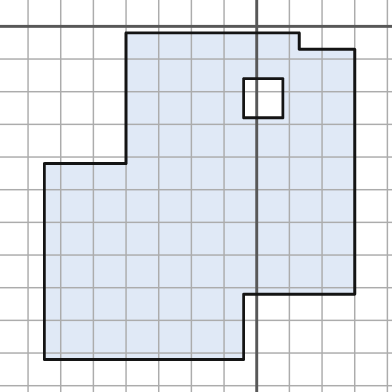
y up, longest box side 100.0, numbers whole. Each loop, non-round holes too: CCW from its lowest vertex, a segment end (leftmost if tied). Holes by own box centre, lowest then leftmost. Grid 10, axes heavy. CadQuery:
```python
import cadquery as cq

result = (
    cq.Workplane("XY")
    .moveTo(-65.0, -102.0)
    .lineTo(-4.0, -102.0)
    .lineTo(-4.0, -82.0)
    .lineTo(30.0, -82.0)
    .lineTo(30.0, -7.0)
    .lineTo(13.0, -7.0)
    .lineTo(13.0, -2.0)
    .lineTo(-40.0, -2.0)
    .lineTo(-40.0, -42.0)
    .lineTo(-65.0, -42.0)
    .close()
    .moveTo(-4.0, -28.0)
    .lineTo(8.0, -28.0)
    .lineTo(8.0, -16.0)
    .lineTo(-4.0, -16.0)
    .close()
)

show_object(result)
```